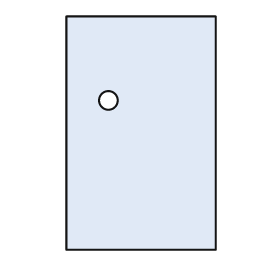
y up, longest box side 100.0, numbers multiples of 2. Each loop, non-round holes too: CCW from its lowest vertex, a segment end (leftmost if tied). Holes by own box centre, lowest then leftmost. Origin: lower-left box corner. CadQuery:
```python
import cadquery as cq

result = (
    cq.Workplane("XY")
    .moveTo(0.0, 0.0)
    .lineTo(64.0, 0.0)
    .lineTo(64.0, 100.0)
    .lineTo(0.0, 100.0)
    .close()
    .moveTo(18.0, 64.0)
    .circle(4.0)
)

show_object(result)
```